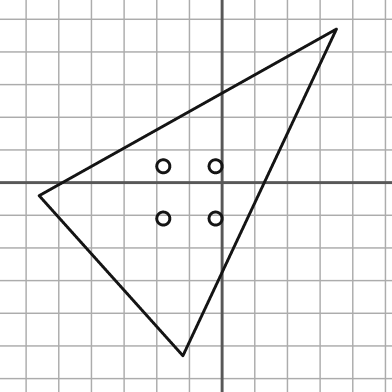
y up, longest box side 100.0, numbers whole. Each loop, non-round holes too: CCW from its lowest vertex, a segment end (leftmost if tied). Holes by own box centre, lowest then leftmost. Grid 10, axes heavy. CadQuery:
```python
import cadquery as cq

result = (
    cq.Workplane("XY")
    .moveTo(-12.0, -53.0)
    .lineTo(35.0, 47.0)
    .lineTo(-56.0, -4.0)
    .close()
    .moveTo(-18.0, -11.0)
    .circle(2.0)
    .moveTo(-2.0, -11.0)
    .circle(2.0)
    .moveTo(-18.0, 5.0)
    .circle(2.0)
    .moveTo(-2.0, 5.0)
    .circle(2.0)
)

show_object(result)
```